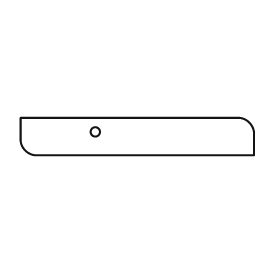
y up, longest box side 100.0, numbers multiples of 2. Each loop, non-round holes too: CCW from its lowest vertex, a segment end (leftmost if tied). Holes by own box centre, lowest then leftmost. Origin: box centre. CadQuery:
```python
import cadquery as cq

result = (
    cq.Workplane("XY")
    .moveTo(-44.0, -8.0)
    .lineTo(50.0, -8.0)
    .lineTo(50.0, 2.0)
    .threePointArc((48.0, 6.0), (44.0, 8.0))
    .lineTo(-50.0, 8.0)
    .lineTo(-50.0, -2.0)
    .threePointArc((-48.0, -6.0), (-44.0, -8.0))
    .close()
    .moveTo(-18.0, 2.0)
    .circle(2.0)
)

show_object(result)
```